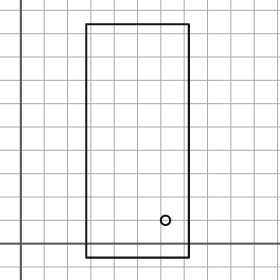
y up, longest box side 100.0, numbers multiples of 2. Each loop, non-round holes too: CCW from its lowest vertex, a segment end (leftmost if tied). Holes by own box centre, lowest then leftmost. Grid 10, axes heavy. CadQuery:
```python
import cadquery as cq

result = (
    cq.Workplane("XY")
    .moveTo(28.0, -6.0)
    .lineTo(72.0, -6.0)
    .lineTo(72.0, 94.0)
    .lineTo(28.0, 94.0)
    .close()
    .moveTo(62.0, 10.0)
    .circle(2.0)
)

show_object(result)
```